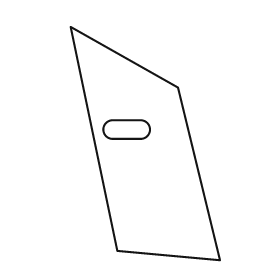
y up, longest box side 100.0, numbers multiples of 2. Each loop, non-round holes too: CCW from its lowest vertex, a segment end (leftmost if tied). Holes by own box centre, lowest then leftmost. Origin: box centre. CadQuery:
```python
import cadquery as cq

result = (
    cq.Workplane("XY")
    .moveTo(32.0, -50.0)
    .lineTo(14.0, 24.0)
    .lineTo(-32.0, 50.0)
    .lineTo(-12.0, -46.0)
    .close()
    .moveTo(-14.0, 2.0)
    .lineTo(-2.0, 2.0)
    .threePointArc((2.0, 6.0), (-2.0, 10.0))
    .lineTo(-14.0, 10.0)
    .threePointArc((-18.0, 6.0), (-14.0, 2.0))
    .close()
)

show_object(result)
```